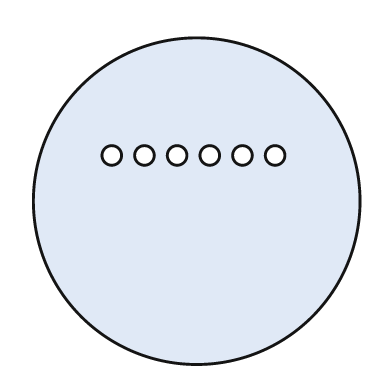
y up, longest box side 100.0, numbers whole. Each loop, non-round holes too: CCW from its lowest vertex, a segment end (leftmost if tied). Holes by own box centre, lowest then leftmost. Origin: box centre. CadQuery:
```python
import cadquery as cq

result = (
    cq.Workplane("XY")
    .moveTo(0.0, 0.0)
    .circle(50.0)
    .moveTo(-26.0, 14.0)
    .circle(3.0)
    .moveTo(-16.0, 14.0)
    .circle(3.0)
    .moveTo(-6.0, 14.0)
    .circle(3.0)
    .moveTo(4.0, 14.0)
    .circle(3.0)
    .moveTo(14.0, 14.0)
    .circle(3.0)
    .moveTo(24.0, 14.0)
    .circle(3.0)
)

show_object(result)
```